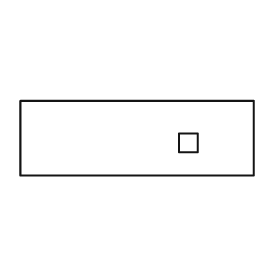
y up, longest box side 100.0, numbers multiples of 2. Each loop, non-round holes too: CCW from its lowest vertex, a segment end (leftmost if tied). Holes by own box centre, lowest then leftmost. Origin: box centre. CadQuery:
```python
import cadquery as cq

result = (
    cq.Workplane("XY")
    .moveTo(-50.0, -16.0)
    .lineTo(50.0, -16.0)
    .lineTo(50.0, 16.0)
    .lineTo(-50.0, 16.0)
    .close()
    .moveTo(18.0, -6.0)
    .lineTo(26.0, -6.0)
    .lineTo(26.0, 2.0)
    .lineTo(18.0, 2.0)
    .close()
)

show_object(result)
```